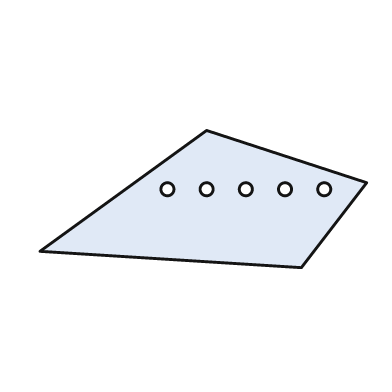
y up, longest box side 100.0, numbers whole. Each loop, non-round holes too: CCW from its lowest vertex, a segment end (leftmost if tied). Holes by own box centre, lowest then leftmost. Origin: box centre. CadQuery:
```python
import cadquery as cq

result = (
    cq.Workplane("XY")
    .moveTo(30.0, -21.0)
    .lineTo(50.0, 5.0)
    .lineTo(1.0, 21.0)
    .lineTo(-50.0, -16.0)
    .close()
    .moveTo(-11.0, 3.0)
    .circle(2.0)
    .moveTo(1.0, 3.0)
    .circle(2.0)
    .moveTo(13.0, 3.0)
    .circle(2.0)
    .moveTo(25.0, 3.0)
    .circle(2.0)
    .moveTo(37.0, 3.0)
    .circle(2.0)
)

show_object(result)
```